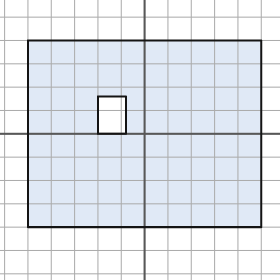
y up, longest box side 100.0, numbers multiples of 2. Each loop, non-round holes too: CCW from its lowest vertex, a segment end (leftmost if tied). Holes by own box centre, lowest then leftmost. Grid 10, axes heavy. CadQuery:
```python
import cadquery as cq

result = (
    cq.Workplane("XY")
    .moveTo(-50.0, -40.0)
    .lineTo(50.0, -40.0)
    .lineTo(50.0, 40.0)
    .lineTo(-50.0, 40.0)
    .close()
    .moveTo(-20.0, 0.0)
    .lineTo(-8.0, 0.0)
    .lineTo(-8.0, 16.0)
    .lineTo(-20.0, 16.0)
    .close()
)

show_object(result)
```